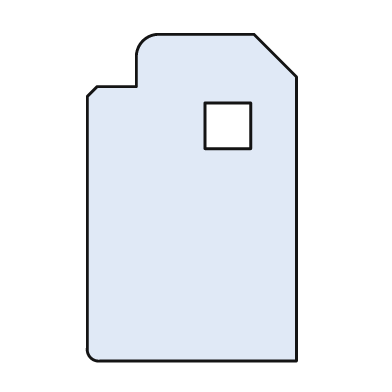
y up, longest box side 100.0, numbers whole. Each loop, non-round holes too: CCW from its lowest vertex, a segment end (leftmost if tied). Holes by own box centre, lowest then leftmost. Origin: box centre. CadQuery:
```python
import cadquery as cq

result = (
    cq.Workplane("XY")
    .moveTo(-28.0, -50.0)
    .lineTo(32.0, -50.0)
    .lineTo(32.0, 37.0)
    .lineTo(19.0, 50.0)
    .lineTo(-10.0, 50.0)
    .threePointArc((-15.0, 48.0), (-17.0, 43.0))
    .lineTo(-17.0, 34.0)
    .lineTo(-29.0, 34.0)
    .lineTo(-32.0, 31.0)
    .lineTo(-32.0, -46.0)
    .threePointArc((-31.0, -49.0), (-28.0, -50.0))
    .close()
    .moveTo(4.0, 15.0)
    .lineTo(18.0, 15.0)
    .lineTo(18.0, 29.0)
    .lineTo(4.0, 29.0)
    .close()
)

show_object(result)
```